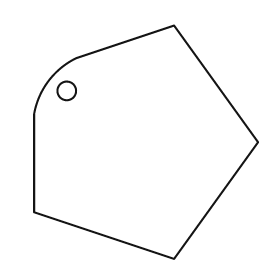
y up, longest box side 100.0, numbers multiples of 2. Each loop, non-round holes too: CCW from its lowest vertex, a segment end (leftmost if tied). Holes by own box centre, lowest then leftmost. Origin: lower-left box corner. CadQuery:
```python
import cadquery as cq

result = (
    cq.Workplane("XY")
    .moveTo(60.0, 0.0)
    .lineTo(96.0, 50.0)
    .lineTo(60.0, 100.0)
    .lineTo(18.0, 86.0)
    .threePointArc((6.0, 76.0), (0.0, 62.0))
    .lineTo(0.0, 20.0)
    .close()
    .moveTo(14.0, 72.0)
    .circle(4.0)
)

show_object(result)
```